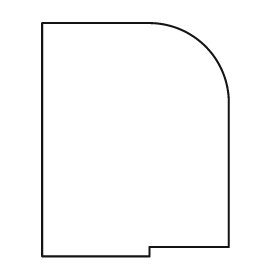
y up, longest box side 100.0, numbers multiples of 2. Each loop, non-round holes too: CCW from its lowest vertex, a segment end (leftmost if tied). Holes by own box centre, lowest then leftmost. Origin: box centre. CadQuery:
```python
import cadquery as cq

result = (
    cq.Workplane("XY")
    .moveTo(-40.0, -50.0)
    .lineTo(6.0, -50.0)
    .lineTo(6.0, -46.0)
    .lineTo(40.0, -46.0)
    .lineTo(40.0, 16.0)
    .threePointArc((30.0, 40.0), (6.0, 50.0))
    .lineTo(-40.0, 50.0)
    .close()
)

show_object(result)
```